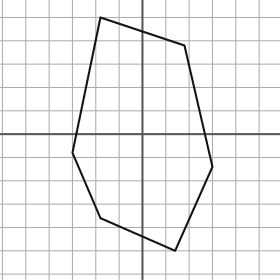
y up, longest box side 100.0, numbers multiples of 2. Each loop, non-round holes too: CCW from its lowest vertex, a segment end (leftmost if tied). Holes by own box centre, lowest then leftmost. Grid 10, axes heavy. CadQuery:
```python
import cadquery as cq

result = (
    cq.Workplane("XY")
    .moveTo(14.0, -50.0)
    .lineTo(30.0, -14.0)
    .lineTo(18.0, 38.0)
    .lineTo(-18.0, 50.0)
    .lineTo(-30.0, -8.0)
    .lineTo(-18.0, -36.0)
    .close()
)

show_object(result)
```